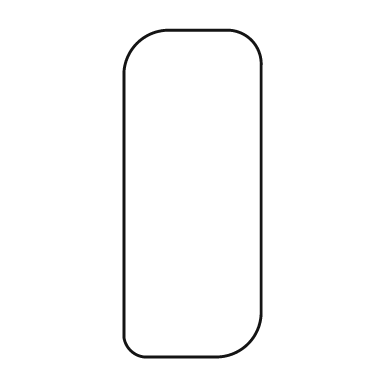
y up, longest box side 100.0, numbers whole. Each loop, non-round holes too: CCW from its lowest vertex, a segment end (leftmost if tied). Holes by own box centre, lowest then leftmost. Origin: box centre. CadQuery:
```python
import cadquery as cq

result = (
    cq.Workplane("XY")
    .moveTo(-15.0, -50.0)
    .lineTo(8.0, -50.0)
    .threePointArc((17.0, -46.0), (21.0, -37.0))
    .lineTo(21.0, 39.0)
    .threePointArc((18.0, 47.0), (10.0, 50.0))
    .lineTo(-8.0, 50.0)
    .threePointArc((-17.0, 46.0), (-21.0, 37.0))
    .lineTo(-21.0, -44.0)
    .threePointArc((-19.0, -48.0), (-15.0, -50.0))
    .close()
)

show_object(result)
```